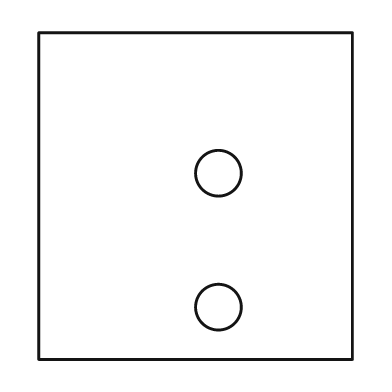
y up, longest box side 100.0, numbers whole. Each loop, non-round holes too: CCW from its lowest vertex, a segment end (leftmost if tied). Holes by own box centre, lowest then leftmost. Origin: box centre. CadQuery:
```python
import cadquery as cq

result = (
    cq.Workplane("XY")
    .moveTo(-48.0, -50.0)
    .lineTo(48.0, -50.0)
    .lineTo(48.0, 50.0)
    .lineTo(-48.0, 50.0)
    .close()
    .moveTo(7.0, -34.0)
    .circle(7.0)
    .moveTo(7.0, 7.0)
    .circle(7.0)
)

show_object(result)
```